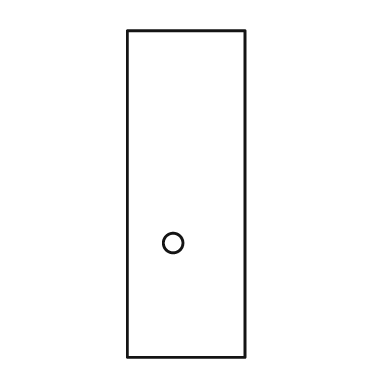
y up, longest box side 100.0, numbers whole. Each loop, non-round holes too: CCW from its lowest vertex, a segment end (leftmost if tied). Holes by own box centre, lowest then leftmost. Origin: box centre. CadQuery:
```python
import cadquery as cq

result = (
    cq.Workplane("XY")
    .moveTo(-18.0, -50.0)
    .lineTo(18.0, -50.0)
    .lineTo(18.0, 50.0)
    .lineTo(-18.0, 50.0)
    .close()
    .moveTo(-4.0, -15.0)
    .circle(3.0)
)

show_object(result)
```